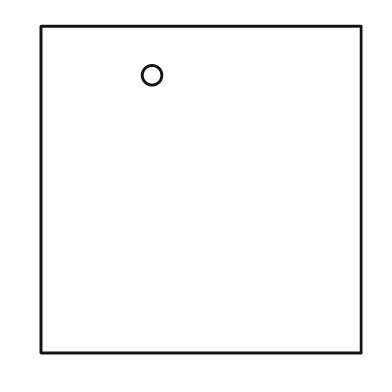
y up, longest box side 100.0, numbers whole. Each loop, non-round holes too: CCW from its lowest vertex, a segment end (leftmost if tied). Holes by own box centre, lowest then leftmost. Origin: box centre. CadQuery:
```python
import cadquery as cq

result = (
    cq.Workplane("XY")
    .moveTo(-49.0, -50.0)
    .lineTo(49.0, -50.0)
    .lineTo(49.0, 50.0)
    .lineTo(-49.0, 50.0)
    .close()
    .moveTo(-15.0, 35.0)
    .circle(3.0)
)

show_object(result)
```